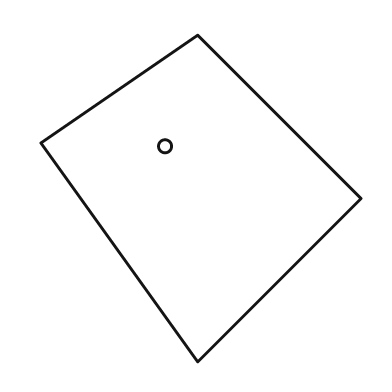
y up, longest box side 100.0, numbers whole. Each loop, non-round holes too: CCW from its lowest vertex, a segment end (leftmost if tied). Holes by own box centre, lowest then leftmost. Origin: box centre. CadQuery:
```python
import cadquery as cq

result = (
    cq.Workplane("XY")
    .moveTo(-1.0, -50.0)
    .lineTo(49.0, 0.0)
    .lineTo(-1.0, 50.0)
    .lineTo(-49.0, 17.0)
    .close()
    .moveTo(-11.0, 16.0)
    .circle(2.0)
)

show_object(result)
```